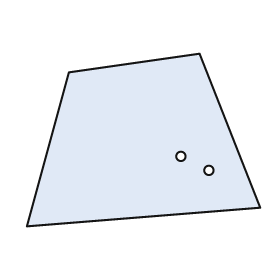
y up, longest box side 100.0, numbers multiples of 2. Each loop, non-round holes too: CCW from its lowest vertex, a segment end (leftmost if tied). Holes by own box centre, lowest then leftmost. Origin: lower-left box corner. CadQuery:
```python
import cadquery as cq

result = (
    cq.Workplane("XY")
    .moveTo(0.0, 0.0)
    .lineTo(100.0, 8.0)
    .lineTo(74.0, 74.0)
    .lineTo(18.0, 66.0)
    .close()
    .moveTo(78.0, 24.0)
    .circle(2.0)
    .moveTo(66.0, 30.0)
    .circle(2.0)
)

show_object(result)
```